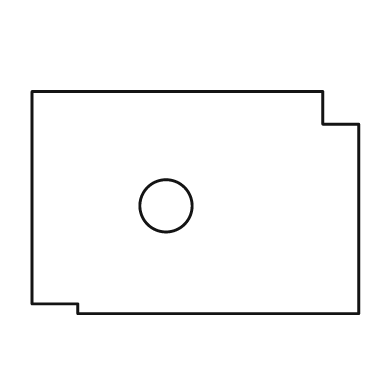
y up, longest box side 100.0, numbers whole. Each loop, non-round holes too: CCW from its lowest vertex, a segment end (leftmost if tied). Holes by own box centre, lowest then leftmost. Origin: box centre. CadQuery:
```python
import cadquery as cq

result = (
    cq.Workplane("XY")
    .moveTo(-36.0, -34.0)
    .lineTo(50.0, -34.0)
    .lineTo(50.0, 24.0)
    .lineTo(39.0, 24.0)
    .lineTo(39.0, 34.0)
    .lineTo(-50.0, 34.0)
    .lineTo(-50.0, -31.0)
    .lineTo(-36.0, -31.0)
    .close()
    .moveTo(-9.0, -1.0)
    .circle(8.0)
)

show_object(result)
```